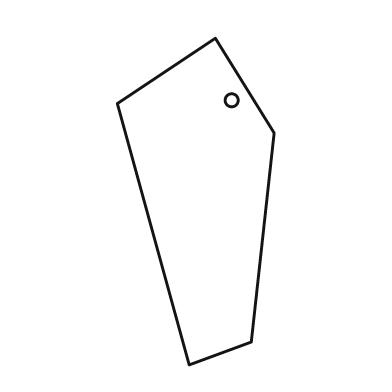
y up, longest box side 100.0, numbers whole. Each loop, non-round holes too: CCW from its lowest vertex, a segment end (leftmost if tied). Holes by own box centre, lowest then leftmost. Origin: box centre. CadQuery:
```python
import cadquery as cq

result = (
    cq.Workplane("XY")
    .moveTo(-2.0, -50.0)
    .lineTo(17.0, -43.0)
    .lineTo(24.0, 21.0)
    .lineTo(6.0, 50.0)
    .lineTo(-24.0, 30.0)
    .close()
    .moveTo(11.0, 31.0)
    .circle(2.0)
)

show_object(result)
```